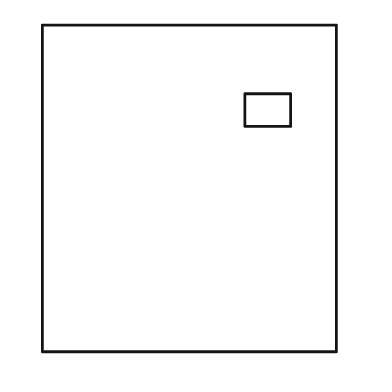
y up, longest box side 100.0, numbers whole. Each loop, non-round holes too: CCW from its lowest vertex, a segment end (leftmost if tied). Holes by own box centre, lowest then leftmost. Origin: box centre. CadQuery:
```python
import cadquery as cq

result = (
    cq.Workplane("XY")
    .moveTo(-45.0, -50.0)
    .lineTo(45.0, -50.0)
    .lineTo(45.0, 50.0)
    .lineTo(-45.0, 50.0)
    .close()
    .moveTo(17.0, 19.0)
    .lineTo(31.0, 19.0)
    .lineTo(31.0, 29.0)
    .lineTo(17.0, 29.0)
    .close()
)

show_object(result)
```